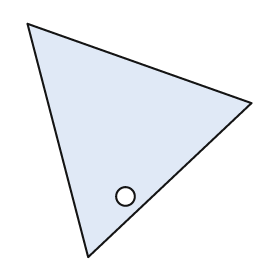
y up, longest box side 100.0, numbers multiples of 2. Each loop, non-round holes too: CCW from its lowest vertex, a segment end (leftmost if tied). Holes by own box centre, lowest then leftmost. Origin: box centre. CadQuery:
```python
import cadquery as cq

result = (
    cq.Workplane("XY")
    .moveTo(-22.0, -50.0)
    .lineTo(48.0, 16.0)
    .lineTo(-48.0, 50.0)
    .close()
    .moveTo(-6.0, -24.0)
    .circle(4.0)
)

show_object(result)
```